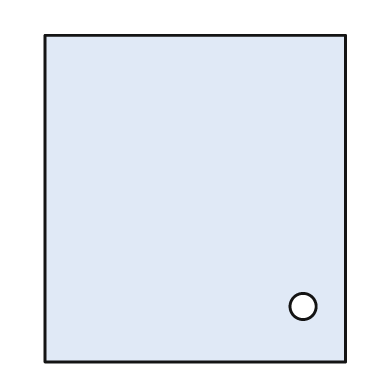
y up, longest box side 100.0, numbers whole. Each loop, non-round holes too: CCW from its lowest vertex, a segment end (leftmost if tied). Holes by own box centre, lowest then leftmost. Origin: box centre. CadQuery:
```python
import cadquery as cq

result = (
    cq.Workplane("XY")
    .moveTo(-46.0, -50.0)
    .lineTo(46.0, -50.0)
    .lineTo(46.0, 50.0)
    .lineTo(-46.0, 50.0)
    .close()
    .moveTo(33.0, -33.0)
    .circle(4.0)
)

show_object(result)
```